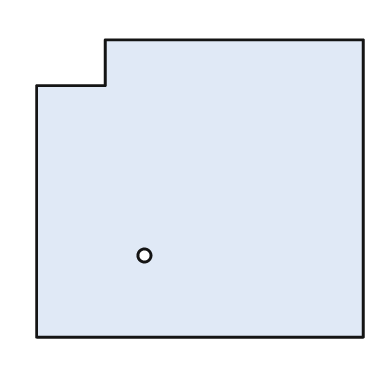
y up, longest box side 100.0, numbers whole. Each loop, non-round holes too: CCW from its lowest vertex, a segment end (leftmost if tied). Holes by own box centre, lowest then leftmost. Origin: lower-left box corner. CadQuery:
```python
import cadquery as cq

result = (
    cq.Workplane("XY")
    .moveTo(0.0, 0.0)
    .lineTo(100.0, 0.0)
    .lineTo(100.0, 91.0)
    .lineTo(21.0, 91.0)
    .lineTo(21.0, 77.0)
    .lineTo(0.0, 77.0)
    .close()
    .moveTo(33.0, 25.0)
    .circle(2.0)
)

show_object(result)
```